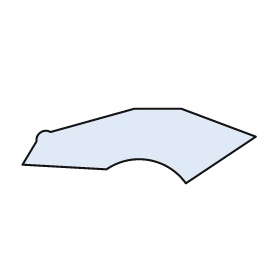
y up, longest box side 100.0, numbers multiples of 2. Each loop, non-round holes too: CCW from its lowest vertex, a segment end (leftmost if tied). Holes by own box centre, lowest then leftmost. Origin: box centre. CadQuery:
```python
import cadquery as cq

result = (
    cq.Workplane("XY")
    .moveTo(20.0, -16.0)
    .lineTo(50.0, 4.0)
    .lineTo(18.0, 16.0)
    .lineTo(-2.0, 16.0)
    .lineTo(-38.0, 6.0)
    .threePointArc((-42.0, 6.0), (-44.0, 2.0))
    .lineTo(-50.0, -8.0)
    .lineTo(-14.0, -10.0)
    .threePointArc((4.0, -6.0), (20.0, -16.0))
    .close()
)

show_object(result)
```